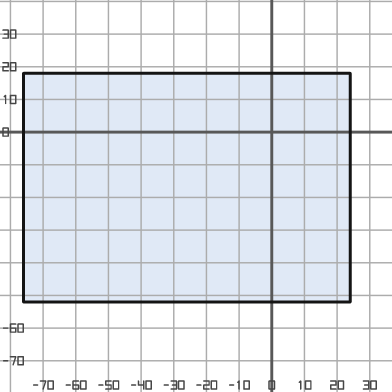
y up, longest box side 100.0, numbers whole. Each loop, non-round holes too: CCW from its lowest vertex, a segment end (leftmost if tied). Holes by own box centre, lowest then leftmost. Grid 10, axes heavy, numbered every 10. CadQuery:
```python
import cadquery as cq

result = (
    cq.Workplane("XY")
    .moveTo(-76.0, -52.0)
    .lineTo(24.0, -52.0)
    .lineTo(24.0, 18.0)
    .lineTo(-76.0, 18.0)
    .close()
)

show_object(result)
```